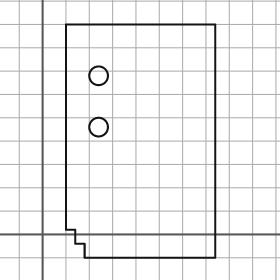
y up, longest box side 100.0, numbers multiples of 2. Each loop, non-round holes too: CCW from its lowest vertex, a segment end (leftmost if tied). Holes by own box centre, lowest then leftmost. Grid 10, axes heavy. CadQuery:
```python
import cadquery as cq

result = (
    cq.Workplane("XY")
    .moveTo(18.0, -10.0)
    .lineTo(74.0, -10.0)
    .lineTo(74.0, 90.0)
    .lineTo(10.0, 90.0)
    .lineTo(10.0, 2.0)
    .lineTo(14.0, 2.0)
    .lineTo(14.0, -4.0)
    .lineTo(18.0, -4.0)
    .close()
    .moveTo(24.0, 46.0)
    .circle(4.0)
    .moveTo(24.0, 68.0)
    .circle(4.0)
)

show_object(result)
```